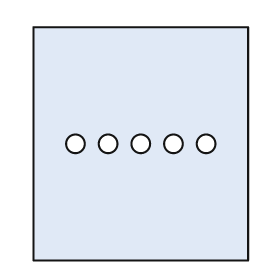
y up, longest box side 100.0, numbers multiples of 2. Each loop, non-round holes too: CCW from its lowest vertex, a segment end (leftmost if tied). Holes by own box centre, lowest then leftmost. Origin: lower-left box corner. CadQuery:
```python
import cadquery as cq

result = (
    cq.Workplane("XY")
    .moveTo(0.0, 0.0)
    .lineTo(92.0, 0.0)
    .lineTo(92.0, 100.0)
    .lineTo(0.0, 100.0)
    .close()
    .moveTo(18.0, 50.0)
    .circle(4.0)
    .moveTo(32.0, 50.0)
    .circle(4.0)
    .moveTo(46.0, 50.0)
    .circle(4.0)
    .moveTo(60.0, 50.0)
    .circle(4.0)
    .moveTo(74.0, 50.0)
    .circle(4.0)
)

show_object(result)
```